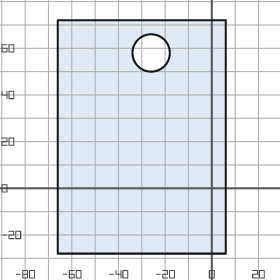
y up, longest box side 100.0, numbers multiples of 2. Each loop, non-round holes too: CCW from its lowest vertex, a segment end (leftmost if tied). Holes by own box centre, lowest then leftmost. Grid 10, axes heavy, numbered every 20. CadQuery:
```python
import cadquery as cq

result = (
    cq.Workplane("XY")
    .moveTo(-66.0, -28.0)
    .lineTo(6.0, -28.0)
    .lineTo(6.0, 72.0)
    .lineTo(-66.0, 72.0)
    .close()
    .moveTo(-26.0, 58.0)
    .circle(8.0)
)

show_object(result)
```